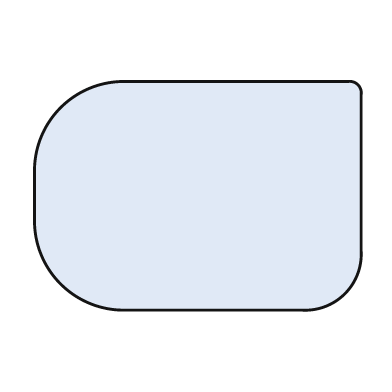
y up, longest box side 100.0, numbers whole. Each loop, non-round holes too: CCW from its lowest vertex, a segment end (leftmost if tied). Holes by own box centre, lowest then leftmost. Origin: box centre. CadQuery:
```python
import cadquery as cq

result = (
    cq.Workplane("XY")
    .moveTo(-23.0, -35.0)
    .lineTo(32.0, -35.0)
    .threePointArc((45.0, -30.0), (50.0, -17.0))
    .lineTo(50.0, 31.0)
    .threePointArc((49.0, 34.0), (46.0, 35.0))
    .lineTo(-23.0, 35.0)
    .threePointArc((-42.0, 27.0), (-50.0, 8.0))
    .lineTo(-50.0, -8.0)
    .threePointArc((-42.0, -27.0), (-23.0, -35.0))
    .close()
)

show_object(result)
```